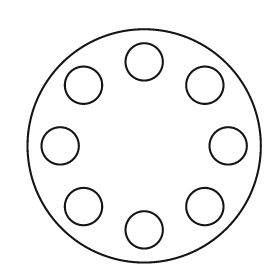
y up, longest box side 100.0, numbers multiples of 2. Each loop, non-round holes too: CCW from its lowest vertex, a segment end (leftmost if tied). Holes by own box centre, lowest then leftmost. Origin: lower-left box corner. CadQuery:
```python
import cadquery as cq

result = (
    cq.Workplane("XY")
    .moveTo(50.0, 50.0)
    .circle(50.0)
    .moveTo(50.0, 14.0)
    .circle(8.0)
    .moveTo(24.0, 24.0)
    .circle(8.0)
    .moveTo(76.0, 24.0)
    .circle(8.0)
    .moveTo(14.0, 50.0)
    .circle(8.0)
    .moveTo(86.0, 50.0)
    .circle(8.0)
    .moveTo(24.0, 76.0)
    .circle(8.0)
    .moveTo(76.0, 76.0)
    .circle(8.0)
    .moveTo(50.0, 86.0)
    .circle(8.0)
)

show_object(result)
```